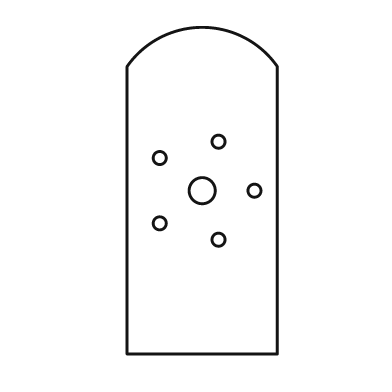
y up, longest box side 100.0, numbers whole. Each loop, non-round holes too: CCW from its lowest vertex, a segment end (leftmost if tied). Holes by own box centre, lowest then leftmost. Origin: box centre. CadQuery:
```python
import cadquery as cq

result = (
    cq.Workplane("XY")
    .moveTo(-23.0, -50.0)
    .lineTo(23.0, -50.0)
    .lineTo(23.0, 38.0)
    .threePointArc((0.0, 50.0), (-23.0, 38.0))
    .close()
    .moveTo(5.0, -15.0)
    .circle(2.0)
    .moveTo(-13.0, -10.0)
    .circle(2.0)
    .moveTo(0.0, 0.0)
    .circle(4.0)
    .moveTo(16.0, 0.0)
    .circle(2.0)
    .moveTo(-13.0, 10.0)
    .circle(2.0)
    .moveTo(5.0, 15.0)
    .circle(2.0)
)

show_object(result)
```